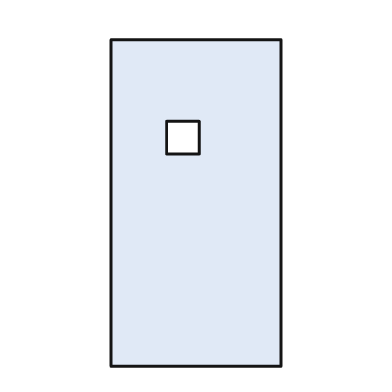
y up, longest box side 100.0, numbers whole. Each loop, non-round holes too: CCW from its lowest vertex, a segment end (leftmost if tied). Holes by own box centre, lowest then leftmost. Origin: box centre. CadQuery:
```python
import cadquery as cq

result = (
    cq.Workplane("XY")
    .moveTo(-26.0, -50.0)
    .lineTo(26.0, -50.0)
    .lineTo(26.0, 50.0)
    .lineTo(-26.0, 50.0)
    .close()
    .moveTo(-9.0, 15.0)
    .lineTo(1.0, 15.0)
    .lineTo(1.0, 25.0)
    .lineTo(-9.0, 25.0)
    .close()
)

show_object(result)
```